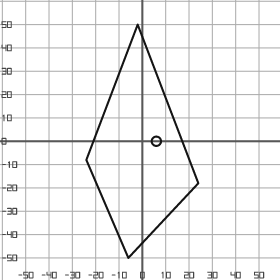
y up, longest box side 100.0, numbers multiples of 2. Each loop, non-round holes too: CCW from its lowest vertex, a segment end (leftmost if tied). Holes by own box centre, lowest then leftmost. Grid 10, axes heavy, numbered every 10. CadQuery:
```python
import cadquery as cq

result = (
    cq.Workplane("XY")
    .moveTo(-6.0, -50.0)
    .lineTo(24.0, -18.0)
    .lineTo(-2.0, 50.0)
    .lineTo(-24.0, -8.0)
    .close()
    .moveTo(6.0, 0.0)
    .circle(2.0)
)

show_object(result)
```